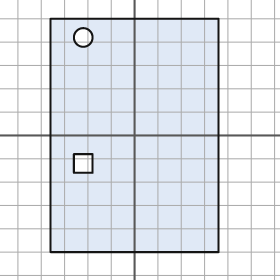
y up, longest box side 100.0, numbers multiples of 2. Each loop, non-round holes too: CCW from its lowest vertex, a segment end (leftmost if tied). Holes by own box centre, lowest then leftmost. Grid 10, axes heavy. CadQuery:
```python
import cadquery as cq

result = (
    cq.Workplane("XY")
    .moveTo(-36.0, -50.0)
    .lineTo(36.0, -50.0)
    .lineTo(36.0, 50.0)
    .lineTo(-36.0, 50.0)
    .close()
    .moveTo(-26.0, -16.0)
    .lineTo(-18.0, -16.0)
    .lineTo(-18.0, -8.0)
    .lineTo(-26.0, -8.0)
    .close()
    .moveTo(-22.0, 42.0)
    .circle(4.0)
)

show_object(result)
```